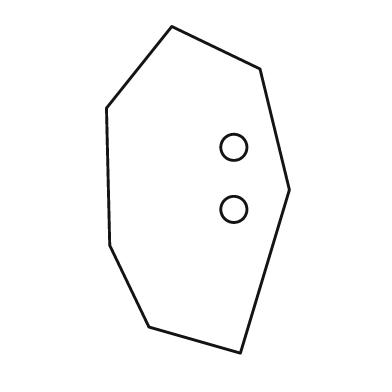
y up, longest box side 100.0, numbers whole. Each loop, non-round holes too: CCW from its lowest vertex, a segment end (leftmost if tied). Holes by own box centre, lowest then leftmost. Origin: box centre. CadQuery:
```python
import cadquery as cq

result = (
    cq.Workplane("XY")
    .moveTo(13.0, -50.0)
    .lineTo(28.0, 0.0)
    .lineTo(19.0, 37.0)
    .lineTo(-8.0, 50.0)
    .lineTo(-28.0, 25.0)
    .lineTo(-27.0, -17.0)
    .lineTo(-15.0, -42.0)
    .close()
    .moveTo(11.0, -6.0)
    .circle(4.0)
    .moveTo(11.0, 13.0)
    .circle(4.0)
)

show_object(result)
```